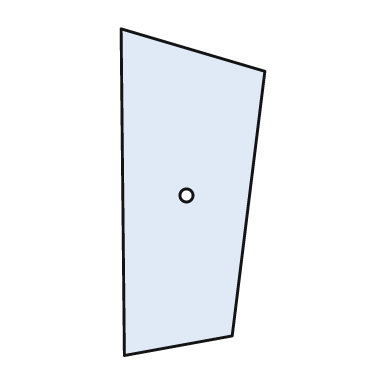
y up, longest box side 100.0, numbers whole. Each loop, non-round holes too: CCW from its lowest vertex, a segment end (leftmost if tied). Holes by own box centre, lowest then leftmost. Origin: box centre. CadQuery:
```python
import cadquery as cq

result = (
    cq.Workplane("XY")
    .moveTo(-21.0, -50.0)
    .lineTo(12.0, -44.0)
    .lineTo(22.0, 37.0)
    .lineTo(-22.0, 50.0)
    .close()
    .moveTo(-2.0, -1.0)
    .circle(2.0)
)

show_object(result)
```